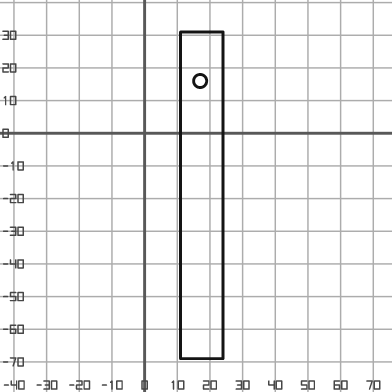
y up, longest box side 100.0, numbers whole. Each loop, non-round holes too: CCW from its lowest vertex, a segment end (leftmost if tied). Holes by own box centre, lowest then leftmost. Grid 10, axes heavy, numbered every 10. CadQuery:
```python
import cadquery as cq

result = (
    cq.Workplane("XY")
    .moveTo(11.0, -69.0)
    .lineTo(24.0, -69.0)
    .lineTo(24.0, 31.0)
    .lineTo(11.0, 31.0)
    .close()
    .moveTo(17.0, 16.0)
    .circle(2.0)
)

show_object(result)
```